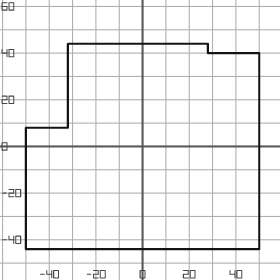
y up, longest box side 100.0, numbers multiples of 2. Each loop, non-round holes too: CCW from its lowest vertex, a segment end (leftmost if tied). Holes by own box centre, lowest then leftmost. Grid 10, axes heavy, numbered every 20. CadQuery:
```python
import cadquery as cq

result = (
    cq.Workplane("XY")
    .moveTo(-50.0, -44.0)
    .lineTo(50.0, -44.0)
    .lineTo(50.0, 40.0)
    .lineTo(28.0, 40.0)
    .lineTo(28.0, 44.0)
    .lineTo(-32.0, 44.0)
    .lineTo(-32.0, 8.0)
    .lineTo(-50.0, 8.0)
    .close()
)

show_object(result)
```